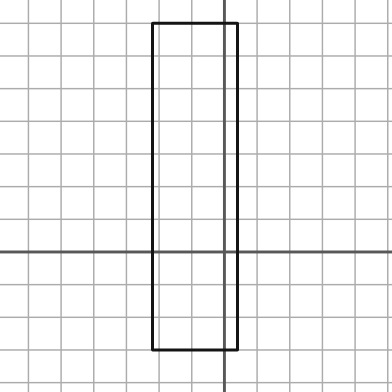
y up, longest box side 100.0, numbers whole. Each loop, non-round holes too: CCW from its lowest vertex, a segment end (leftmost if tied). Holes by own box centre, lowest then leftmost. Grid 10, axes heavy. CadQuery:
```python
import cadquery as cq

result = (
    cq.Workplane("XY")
    .moveTo(-22.0, -30.0)
    .lineTo(4.0, -30.0)
    .lineTo(4.0, 70.0)
    .lineTo(-22.0, 70.0)
    .close()
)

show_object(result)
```